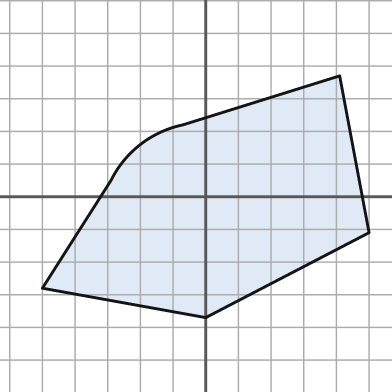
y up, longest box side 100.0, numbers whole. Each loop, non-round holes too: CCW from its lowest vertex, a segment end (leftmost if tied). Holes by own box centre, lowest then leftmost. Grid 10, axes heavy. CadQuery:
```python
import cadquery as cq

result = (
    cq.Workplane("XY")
    .moveTo(0.0, -37.0)
    .lineTo(50.0, -11.0)
    .lineTo(41.0, 37.0)
    .lineTo(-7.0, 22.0)
    .threePointArc((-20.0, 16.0), (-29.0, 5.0))
    .lineTo(-50.0, -28.0)
    .close()
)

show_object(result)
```